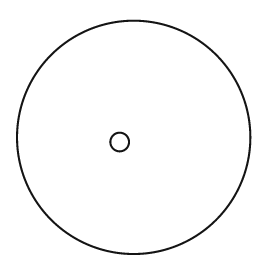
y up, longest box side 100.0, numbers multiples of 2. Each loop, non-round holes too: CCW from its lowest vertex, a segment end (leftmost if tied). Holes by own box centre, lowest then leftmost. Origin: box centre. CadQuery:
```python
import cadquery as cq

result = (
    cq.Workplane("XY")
    .moveTo(0.0, 0.0)
    .circle(50.0)
    .moveTo(-6.0, -2.0)
    .circle(4.0)
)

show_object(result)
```